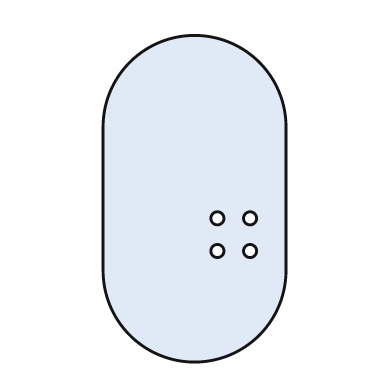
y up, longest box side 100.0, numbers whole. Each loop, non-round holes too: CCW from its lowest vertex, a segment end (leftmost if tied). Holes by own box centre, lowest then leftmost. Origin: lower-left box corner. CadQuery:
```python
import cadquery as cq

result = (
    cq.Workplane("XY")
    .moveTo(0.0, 28.0)
    .threePointArc((28.0, 0.0), (56.0, 28.0))
    .lineTo(56.0, 72.0)
    .threePointArc((28.0, 100.0), (0.0, 72.0))
    .close()
    .moveTo(35.0, 34.0)
    .circle(2.0)
    .moveTo(45.0, 34.0)
    .circle(2.0)
    .moveTo(35.0, 44.0)
    .circle(2.0)
    .moveTo(45.0, 44.0)
    .circle(2.0)
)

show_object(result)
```